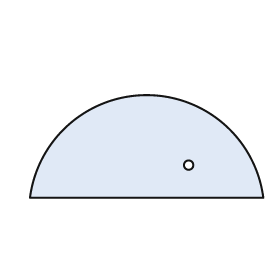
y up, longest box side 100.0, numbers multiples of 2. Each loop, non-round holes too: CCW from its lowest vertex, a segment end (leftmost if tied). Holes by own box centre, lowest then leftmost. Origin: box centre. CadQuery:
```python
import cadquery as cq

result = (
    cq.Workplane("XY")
    .moveTo(-50.0, -22.0)
    .lineTo(50.0, -22.0)
    .threePointArc((0.0, 22.0), (-50.0, -22.0))
    .close()
    .moveTo(18.0, -8.0)
    .circle(2.0)
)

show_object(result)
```